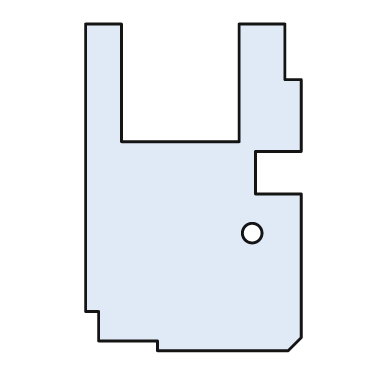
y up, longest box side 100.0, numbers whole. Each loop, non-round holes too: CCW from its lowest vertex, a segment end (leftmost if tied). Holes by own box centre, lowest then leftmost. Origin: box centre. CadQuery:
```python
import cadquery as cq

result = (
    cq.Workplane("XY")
    .moveTo(-11.0, -50.0)
    .lineTo(29.0, -50.0)
    .lineTo(33.0, -46.0)
    .lineTo(33.0, -2.0)
    .lineTo(19.0, -2.0)
    .lineTo(19.0, 11.0)
    .lineTo(33.0, 11.0)
    .lineTo(33.0, 33.0)
    .lineTo(28.0, 33.0)
    .lineTo(28.0, 50.0)
    .lineTo(14.0, 50.0)
    .lineTo(14.0, 14.0)
    .lineTo(-22.0, 14.0)
    .lineTo(-22.0, 50.0)
    .lineTo(-33.0, 50.0)
    .lineTo(-33.0, -38.0)
    .lineTo(-29.0, -38.0)
    .lineTo(-29.0, -47.0)
    .lineTo(-11.0, -47.0)
    .close()
    .moveTo(18.0, -14.0)
    .circle(3.0)
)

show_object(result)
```